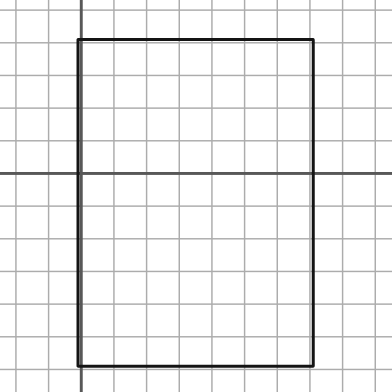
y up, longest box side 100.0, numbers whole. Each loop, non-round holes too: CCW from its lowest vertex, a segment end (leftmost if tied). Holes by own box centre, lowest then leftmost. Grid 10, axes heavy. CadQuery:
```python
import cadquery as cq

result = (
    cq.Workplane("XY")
    .moveTo(-1.0, -59.0)
    .lineTo(71.0, -59.0)
    .lineTo(71.0, 41.0)
    .lineTo(-1.0, 41.0)
    .close()
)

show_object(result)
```